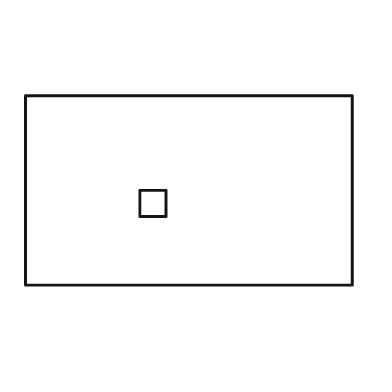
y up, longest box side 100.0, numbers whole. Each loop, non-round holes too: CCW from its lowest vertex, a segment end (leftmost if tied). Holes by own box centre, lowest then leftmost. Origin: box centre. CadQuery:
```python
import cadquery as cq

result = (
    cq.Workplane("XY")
    .moveTo(-50.0, -29.0)
    .lineTo(50.0, -29.0)
    .lineTo(50.0, 29.0)
    .lineTo(-50.0, 29.0)
    .close()
    .moveTo(-15.0, -8.0)
    .lineTo(-7.0, -8.0)
    .lineTo(-7.0, 0.0)
    .lineTo(-15.0, 0.0)
    .close()
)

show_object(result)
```